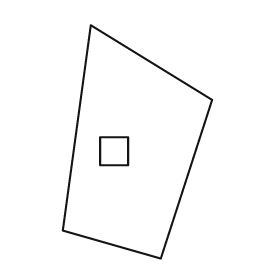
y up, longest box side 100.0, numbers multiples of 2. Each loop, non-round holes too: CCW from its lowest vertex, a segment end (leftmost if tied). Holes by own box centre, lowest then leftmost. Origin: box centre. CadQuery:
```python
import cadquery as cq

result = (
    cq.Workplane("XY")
    .moveTo(10.0, -50.0)
    .lineTo(32.0, 18.0)
    .lineTo(-20.0, 50.0)
    .lineTo(-32.0, -38.0)
    .close()
    .moveTo(-16.0, -10.0)
    .lineTo(-4.0, -10.0)
    .lineTo(-4.0, 2.0)
    .lineTo(-16.0, 2.0)
    .close()
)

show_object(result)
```